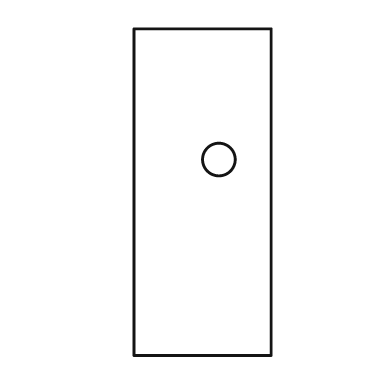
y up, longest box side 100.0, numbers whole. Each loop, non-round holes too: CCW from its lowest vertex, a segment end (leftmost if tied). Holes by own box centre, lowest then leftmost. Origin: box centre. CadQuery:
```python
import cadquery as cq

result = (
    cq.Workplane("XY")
    .moveTo(-21.0, -50.0)
    .lineTo(21.0, -50.0)
    .lineTo(21.0, 50.0)
    .lineTo(-21.0, 50.0)
    .close()
    .moveTo(5.0, 10.0)
    .circle(5.0)
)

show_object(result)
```